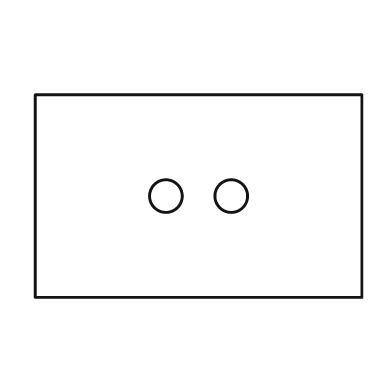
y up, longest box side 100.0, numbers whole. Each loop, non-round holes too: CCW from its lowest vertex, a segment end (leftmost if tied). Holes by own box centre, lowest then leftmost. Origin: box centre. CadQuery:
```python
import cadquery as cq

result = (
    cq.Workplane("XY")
    .moveTo(-50.0, -31.0)
    .lineTo(50.0, -31.0)
    .lineTo(50.0, 31.0)
    .lineTo(-50.0, 31.0)
    .close()
    .moveTo(-10.0, 0.0)
    .circle(5.0)
    .moveTo(10.0, 0.0)
    .circle(5.0)
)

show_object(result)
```